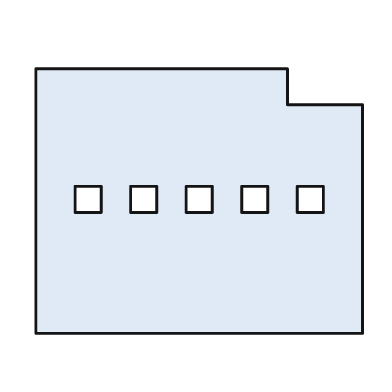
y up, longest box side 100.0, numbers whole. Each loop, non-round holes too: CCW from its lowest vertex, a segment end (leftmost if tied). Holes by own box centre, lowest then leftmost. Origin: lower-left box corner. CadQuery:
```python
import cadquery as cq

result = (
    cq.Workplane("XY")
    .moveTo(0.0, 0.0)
    .lineTo(100.0, 0.0)
    .lineTo(100.0, 70.0)
    .lineTo(77.0, 70.0)
    .lineTo(77.0, 81.0)
    .lineTo(0.0, 81.0)
    .close()
    .moveTo(12.0, 37.0)
    .lineTo(20.0, 37.0)
    .lineTo(20.0, 45.0)
    .lineTo(12.0, 45.0)
    .close()
    .moveTo(29.0, 37.0)
    .lineTo(37.0, 37.0)
    .lineTo(37.0, 45.0)
    .lineTo(29.0, 45.0)
    .close()
    .moveTo(46.0, 37.0)
    .lineTo(54.0, 37.0)
    .lineTo(54.0, 45.0)
    .lineTo(46.0, 45.0)
    .close()
    .moveTo(63.0, 37.0)
    .lineTo(71.0, 37.0)
    .lineTo(71.0, 45.0)
    .lineTo(63.0, 45.0)
    .close()
    .moveTo(80.0, 37.0)
    .lineTo(88.0, 37.0)
    .lineTo(88.0, 45.0)
    .lineTo(80.0, 45.0)
    .close()
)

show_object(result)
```